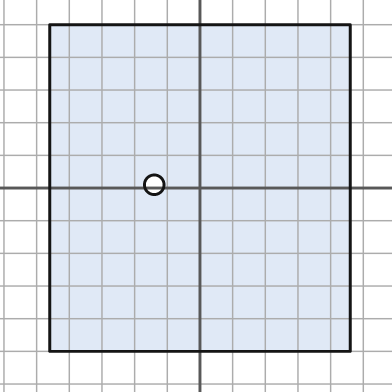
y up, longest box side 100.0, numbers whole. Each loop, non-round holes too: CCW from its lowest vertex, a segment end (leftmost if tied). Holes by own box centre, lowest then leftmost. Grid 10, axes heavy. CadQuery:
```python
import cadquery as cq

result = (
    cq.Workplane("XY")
    .moveTo(-46.0, -50.0)
    .lineTo(46.0, -50.0)
    .lineTo(46.0, 50.0)
    .lineTo(-46.0, 50.0)
    .close()
    .moveTo(-14.0, 1.0)
    .circle(3.0)
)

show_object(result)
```